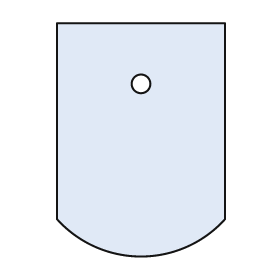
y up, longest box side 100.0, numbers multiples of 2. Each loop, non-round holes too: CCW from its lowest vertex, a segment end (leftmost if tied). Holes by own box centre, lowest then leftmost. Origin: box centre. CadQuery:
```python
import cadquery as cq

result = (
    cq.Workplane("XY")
    .moveTo(-36.0, -34.0)
    .threePointArc((0.0, -50.0), (36.0, -34.0))
    .lineTo(36.0, 50.0)
    .lineTo(-36.0, 50.0)
    .close()
    .moveTo(0.0, 24.0)
    .circle(4.0)
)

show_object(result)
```